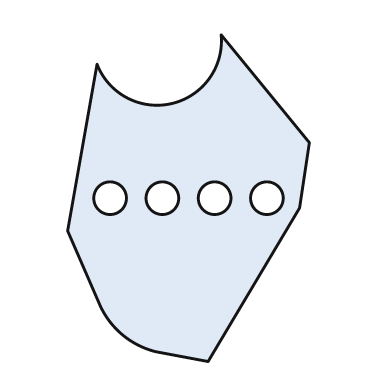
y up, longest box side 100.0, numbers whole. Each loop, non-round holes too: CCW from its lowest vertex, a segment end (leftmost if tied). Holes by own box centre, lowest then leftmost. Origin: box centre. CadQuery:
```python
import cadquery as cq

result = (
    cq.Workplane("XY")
    .moveTo(6.0, -50.0)
    .lineTo(34.0, -3.0)
    .lineTo(37.0, 17.0)
    .lineTo(10.0, 50.0)
    .threePointArc((-5.0, 29.0), (-28.0, 41.0))
    .lineTo(-37.0, -10.0)
    .lineTo(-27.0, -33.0)
    .threePointArc((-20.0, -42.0), (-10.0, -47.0))
    .close()
    .moveTo(-24.0, 0.0)
    .circle(5.0)
    .moveTo(-8.0, 0.0)
    .circle(5.0)
    .moveTo(8.0, 0.0)
    .circle(5.0)
    .moveTo(24.0, 0.0)
    .circle(5.0)
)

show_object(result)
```